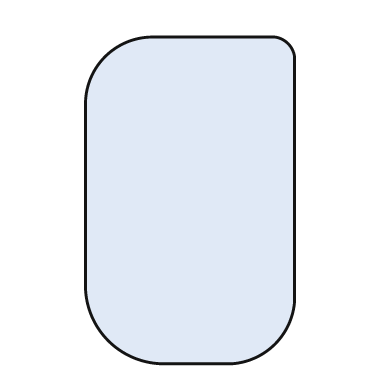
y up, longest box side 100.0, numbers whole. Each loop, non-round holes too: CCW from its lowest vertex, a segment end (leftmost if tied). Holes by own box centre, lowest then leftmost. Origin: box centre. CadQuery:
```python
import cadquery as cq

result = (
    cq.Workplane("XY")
    .moveTo(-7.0, -50.0)
    .lineTo(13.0, -50.0)
    .threePointArc((26.0, -44.0), (32.0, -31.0))
    .lineTo(32.0, 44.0)
    .threePointArc((30.0, 48.0), (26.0, 50.0))
    .lineTo(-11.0, 50.0)
    .threePointArc((-26.0, 44.0), (-32.0, 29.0))
    .lineTo(-32.0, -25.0)
    .threePointArc((-25.0, -43.0), (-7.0, -50.0))
    .close()
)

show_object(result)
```